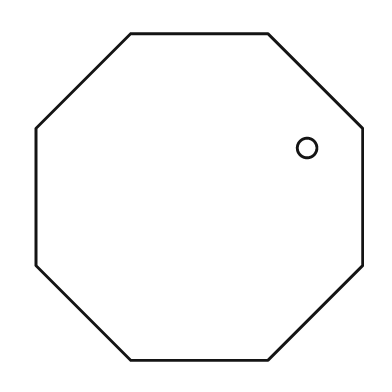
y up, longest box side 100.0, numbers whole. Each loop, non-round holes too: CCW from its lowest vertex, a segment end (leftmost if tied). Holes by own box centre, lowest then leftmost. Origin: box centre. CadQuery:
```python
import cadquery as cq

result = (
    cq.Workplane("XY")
    .moveTo(-21.0, -50.0)
    .lineTo(21.0, -50.0)
    .lineTo(50.0, -21.0)
    .lineTo(50.0, 21.0)
    .lineTo(21.0, 50.0)
    .lineTo(-21.0, 50.0)
    .lineTo(-50.0, 21.0)
    .lineTo(-50.0, -21.0)
    .close()
    .moveTo(33.0, 15.0)
    .circle(3.0)
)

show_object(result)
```